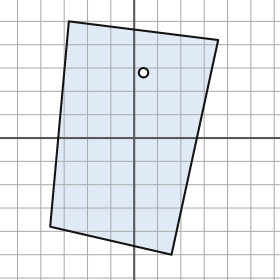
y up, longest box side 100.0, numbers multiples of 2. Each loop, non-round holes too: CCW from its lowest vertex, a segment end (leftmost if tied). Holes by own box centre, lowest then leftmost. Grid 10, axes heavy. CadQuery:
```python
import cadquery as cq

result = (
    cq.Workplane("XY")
    .moveTo(16.0, -50.0)
    .lineTo(36.0, 42.0)
    .lineTo(-28.0, 50.0)
    .lineTo(-36.0, -38.0)
    .close()
    .moveTo(4.0, 28.0)
    .circle(2.0)
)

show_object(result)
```